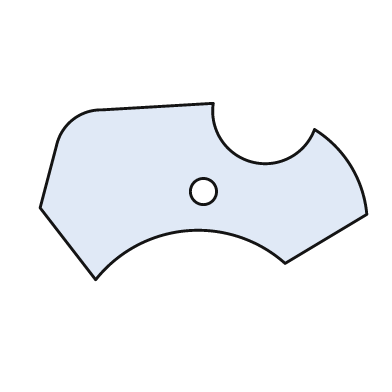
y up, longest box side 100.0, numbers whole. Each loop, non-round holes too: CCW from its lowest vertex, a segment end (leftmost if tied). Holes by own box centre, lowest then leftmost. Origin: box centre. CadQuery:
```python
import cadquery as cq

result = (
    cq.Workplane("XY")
    .moveTo(-33.0, -27.0)
    .threePointArc((-5.0, -12.0), (25.0, -22.0))
    .lineTo(50.0, -7.0)
    .threePointArc((45.0, 8.0), (34.0, 19.0))
    .threePointArc((15.0, 9.0), (3.0, 27.0))
    .lineTo(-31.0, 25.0)
    .threePointArc((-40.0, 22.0), (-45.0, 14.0))
    .lineTo(-50.0, -5.0)
    .close()
    .moveTo(0.0, 0.0)
    .circle(4.0)
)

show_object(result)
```